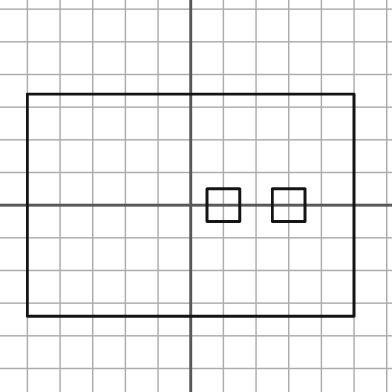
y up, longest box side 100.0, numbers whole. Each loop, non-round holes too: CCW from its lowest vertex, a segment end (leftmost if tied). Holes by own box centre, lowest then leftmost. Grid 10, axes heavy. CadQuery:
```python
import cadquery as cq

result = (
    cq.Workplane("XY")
    .moveTo(-50.0, -34.0)
    .lineTo(50.0, -34.0)
    .lineTo(50.0, 34.0)
    .lineTo(-50.0, 34.0)
    .close()
    .moveTo(5.0, -5.0)
    .lineTo(15.0, -5.0)
    .lineTo(15.0, 5.0)
    .lineTo(5.0, 5.0)
    .close()
    .moveTo(25.0, -5.0)
    .lineTo(35.0, -5.0)
    .lineTo(35.0, 5.0)
    .lineTo(25.0, 5.0)
    .close()
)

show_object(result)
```